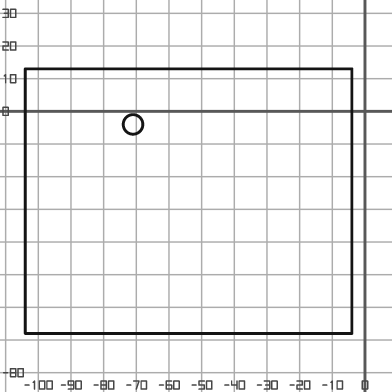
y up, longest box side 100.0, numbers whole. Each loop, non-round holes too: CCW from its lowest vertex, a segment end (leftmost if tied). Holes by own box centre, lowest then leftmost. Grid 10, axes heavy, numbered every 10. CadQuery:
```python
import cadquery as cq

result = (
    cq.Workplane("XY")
    .moveTo(-104.0, -68.0)
    .lineTo(-4.0, -68.0)
    .lineTo(-4.0, 13.0)
    .lineTo(-104.0, 13.0)
    .close()
    .moveTo(-71.0, -4.0)
    .circle(3.0)
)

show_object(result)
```